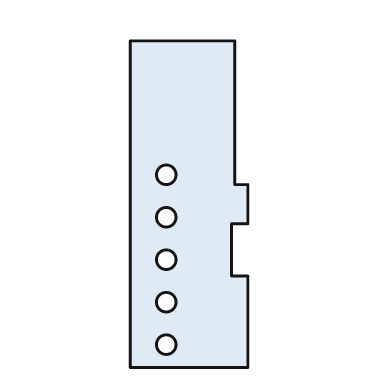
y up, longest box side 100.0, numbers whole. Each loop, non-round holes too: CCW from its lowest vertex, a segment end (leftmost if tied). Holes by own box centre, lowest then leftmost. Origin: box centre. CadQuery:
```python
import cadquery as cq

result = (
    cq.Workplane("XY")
    .moveTo(-18.0, -50.0)
    .lineTo(18.0, -50.0)
    .lineTo(18.0, -22.0)
    .lineTo(13.0, -22.0)
    .lineTo(13.0, -6.0)
    .lineTo(18.0, -6.0)
    .lineTo(18.0, 6.0)
    .lineTo(14.0, 6.0)
    .lineTo(14.0, 50.0)
    .lineTo(-18.0, 50.0)
    .close()
    .moveTo(-7.0, -43.0)
    .circle(3.0)
    .moveTo(-7.0, -30.0)
    .circle(3.0)
    .moveTo(-7.0, -17.0)
    .circle(3.0)
    .moveTo(-7.0, -4.0)
    .circle(3.0)
    .moveTo(-7.0, 9.0)
    .circle(3.0)
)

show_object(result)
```